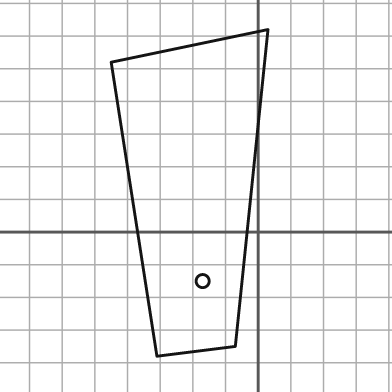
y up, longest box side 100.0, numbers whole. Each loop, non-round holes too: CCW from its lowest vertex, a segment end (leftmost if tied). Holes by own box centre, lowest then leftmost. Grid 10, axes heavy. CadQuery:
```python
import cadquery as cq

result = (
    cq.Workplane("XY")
    .moveTo(-31.0, -38.0)
    .lineTo(-7.0, -35.0)
    .lineTo(3.0, 62.0)
    .lineTo(-45.0, 52.0)
    .close()
    .moveTo(-17.0, -15.0)
    .circle(2.0)
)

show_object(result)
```